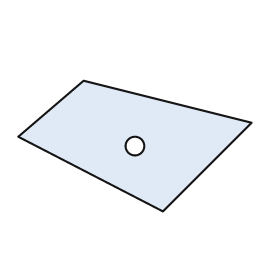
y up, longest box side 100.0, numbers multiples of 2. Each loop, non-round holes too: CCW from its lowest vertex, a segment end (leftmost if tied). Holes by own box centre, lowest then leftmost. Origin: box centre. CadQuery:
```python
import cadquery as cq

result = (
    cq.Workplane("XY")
    .moveTo(12.0, -28.0)
    .lineTo(50.0, 10.0)
    .lineTo(-22.0, 28.0)
    .lineTo(-50.0, 4.0)
    .close()
    .moveTo(0.0, 0.0)
    .circle(4.0)
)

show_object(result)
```